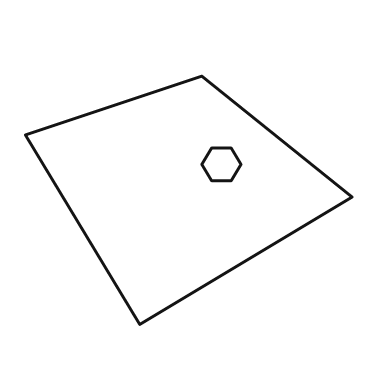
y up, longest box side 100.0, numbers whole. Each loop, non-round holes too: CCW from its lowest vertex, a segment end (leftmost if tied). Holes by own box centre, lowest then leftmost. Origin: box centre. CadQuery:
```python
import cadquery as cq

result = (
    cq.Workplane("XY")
    .moveTo(-15.0, -38.0)
    .lineTo(50.0, 1.0)
    .lineTo(4.0, 38.0)
    .lineTo(-50.0, 20.0)
    .close()
    .moveTo(7.0, 6.0)
    .lineTo(13.0, 6.0)
    .lineTo(16.0, 11.0)
    .lineTo(13.0, 16.0)
    .lineTo(7.0, 16.0)
    .lineTo(4.0, 11.0)
    .close()
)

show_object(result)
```